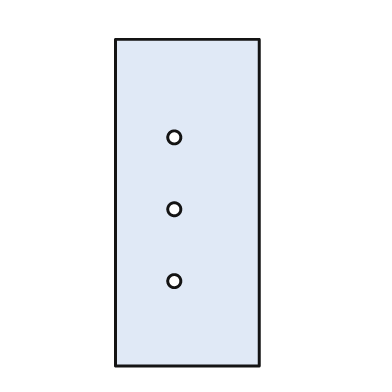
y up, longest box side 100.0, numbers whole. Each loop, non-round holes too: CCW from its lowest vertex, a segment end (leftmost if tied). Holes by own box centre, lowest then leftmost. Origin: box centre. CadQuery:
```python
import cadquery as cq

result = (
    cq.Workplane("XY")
    .moveTo(-22.0, -50.0)
    .lineTo(22.0, -50.0)
    .lineTo(22.0, 50.0)
    .lineTo(-22.0, 50.0)
    .close()
    .moveTo(-4.0, -24.0)
    .circle(2.0)
    .moveTo(-4.0, -2.0)
    .circle(2.0)
    .moveTo(-4.0, 20.0)
    .circle(2.0)
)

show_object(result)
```